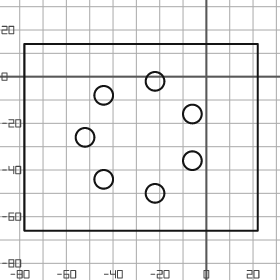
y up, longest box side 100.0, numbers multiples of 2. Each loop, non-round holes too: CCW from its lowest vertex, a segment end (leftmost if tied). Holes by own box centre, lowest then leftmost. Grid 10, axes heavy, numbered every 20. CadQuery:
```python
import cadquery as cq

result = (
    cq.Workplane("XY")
    .moveTo(-78.0, -66.0)
    .lineTo(22.0, -66.0)
    .lineTo(22.0, 14.0)
    .lineTo(-78.0, 14.0)
    .close()
    .moveTo(-22.0, -50.0)
    .circle(4.0)
    .moveTo(-44.0, -44.0)
    .circle(4.0)
    .moveTo(-6.0, -36.0)
    .circle(4.0)
    .moveTo(-52.0, -26.0)
    .circle(4.0)
    .moveTo(-6.0, -16.0)
    .circle(4.0)
    .moveTo(-44.0, -8.0)
    .circle(4.0)
    .moveTo(-22.0, -2.0)
    .circle(4.0)
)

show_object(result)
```